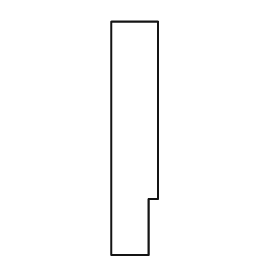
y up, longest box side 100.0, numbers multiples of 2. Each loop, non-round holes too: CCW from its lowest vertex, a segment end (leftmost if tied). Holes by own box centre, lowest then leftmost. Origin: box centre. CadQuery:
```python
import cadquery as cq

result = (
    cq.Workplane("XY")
    .moveTo(-10.0, -50.0)
    .lineTo(6.0, -50.0)
    .lineTo(6.0, -26.0)
    .lineTo(10.0, -26.0)
    .lineTo(10.0, 50.0)
    .lineTo(-10.0, 50.0)
    .close()
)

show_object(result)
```